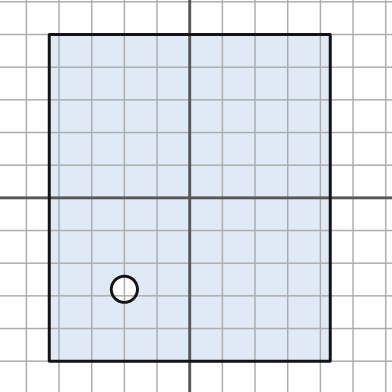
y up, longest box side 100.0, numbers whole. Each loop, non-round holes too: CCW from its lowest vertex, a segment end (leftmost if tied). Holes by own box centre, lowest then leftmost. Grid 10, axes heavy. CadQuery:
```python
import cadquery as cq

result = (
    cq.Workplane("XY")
    .moveTo(-43.0, -50.0)
    .lineTo(43.0, -50.0)
    .lineTo(43.0, 50.0)
    .lineTo(-43.0, 50.0)
    .close()
    .moveTo(-20.0, -28.0)
    .circle(4.0)
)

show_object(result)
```